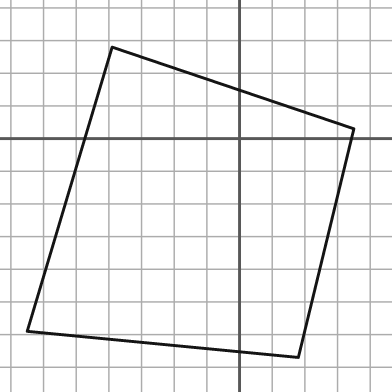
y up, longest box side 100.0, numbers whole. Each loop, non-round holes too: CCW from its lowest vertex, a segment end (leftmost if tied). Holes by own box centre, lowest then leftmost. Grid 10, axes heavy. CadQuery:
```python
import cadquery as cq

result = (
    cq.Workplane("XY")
    .moveTo(18.0, -67.0)
    .lineTo(35.0, 3.0)
    .lineTo(-39.0, 28.0)
    .lineTo(-65.0, -59.0)
    .close()
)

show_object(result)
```